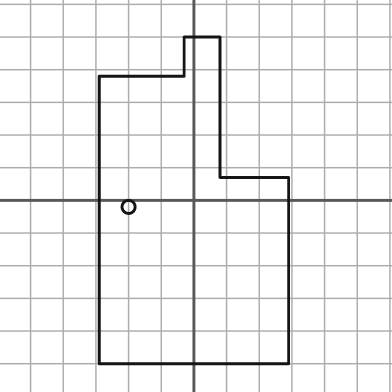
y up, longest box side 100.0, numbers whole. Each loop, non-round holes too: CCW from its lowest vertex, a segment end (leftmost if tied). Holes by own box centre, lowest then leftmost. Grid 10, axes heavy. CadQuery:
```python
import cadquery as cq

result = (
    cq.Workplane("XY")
    .moveTo(-29.0, -50.0)
    .lineTo(29.0, -50.0)
    .lineTo(29.0, 7.0)
    .lineTo(8.0, 7.0)
    .lineTo(8.0, 50.0)
    .lineTo(-3.0, 50.0)
    .lineTo(-3.0, 38.0)
    .lineTo(-29.0, 38.0)
    .close()
    .moveTo(-20.0, -2.0)
    .circle(2.0)
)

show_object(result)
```